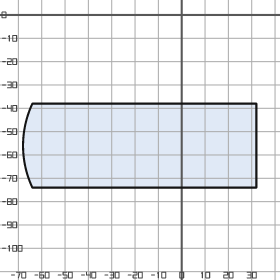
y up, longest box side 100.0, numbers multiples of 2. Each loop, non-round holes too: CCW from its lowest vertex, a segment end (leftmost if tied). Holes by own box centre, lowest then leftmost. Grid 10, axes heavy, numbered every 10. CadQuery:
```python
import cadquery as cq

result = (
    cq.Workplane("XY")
    .moveTo(-64.0, -74.0)
    .lineTo(32.0, -74.0)
    .lineTo(32.0, -38.0)
    .lineTo(-64.0, -38.0)
    .threePointArc((-68.0, -56.0), (-64.0, -74.0))
    .close()
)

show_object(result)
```